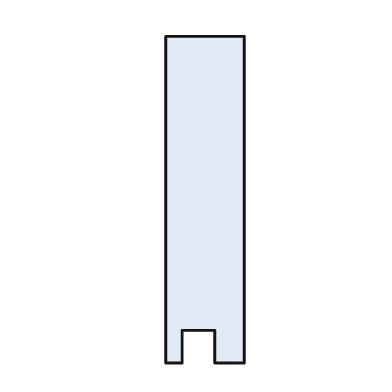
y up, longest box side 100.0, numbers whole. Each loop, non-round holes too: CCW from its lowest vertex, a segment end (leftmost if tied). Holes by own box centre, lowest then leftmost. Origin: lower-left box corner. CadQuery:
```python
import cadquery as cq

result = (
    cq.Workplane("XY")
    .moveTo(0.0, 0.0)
    .lineTo(5.0, 0.0)
    .lineTo(5.0, 10.0)
    .lineTo(15.0, 10.0)
    .lineTo(15.0, 0.0)
    .lineTo(24.0, 0.0)
    .lineTo(24.0, 100.0)
    .lineTo(0.0, 100.0)
    .close()
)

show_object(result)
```